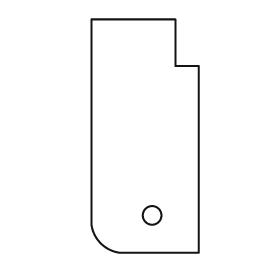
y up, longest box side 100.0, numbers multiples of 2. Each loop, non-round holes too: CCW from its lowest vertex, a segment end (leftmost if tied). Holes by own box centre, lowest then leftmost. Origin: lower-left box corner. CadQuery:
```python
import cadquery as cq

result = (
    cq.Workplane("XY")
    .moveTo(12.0, 0.0)
    .lineTo(46.0, 0.0)
    .lineTo(46.0, 80.0)
    .lineTo(36.0, 80.0)
    .lineTo(36.0, 100.0)
    .lineTo(0.0, 100.0)
    .lineTo(0.0, 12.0)
    .threePointArc((4.0, 4.0), (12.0, 0.0))
    .close()
    .moveTo(26.0, 16.0)
    .circle(4.0)
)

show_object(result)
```